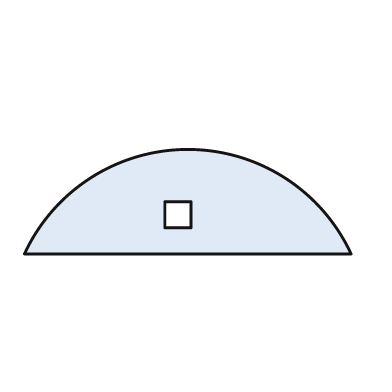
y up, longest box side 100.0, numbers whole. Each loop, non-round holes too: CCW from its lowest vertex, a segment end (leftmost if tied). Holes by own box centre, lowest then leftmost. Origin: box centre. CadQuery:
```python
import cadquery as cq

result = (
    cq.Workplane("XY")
    .moveTo(-50.0, -16.0)
    .lineTo(50.0, -16.0)
    .threePointArc((0.0, 16.0), (-50.0, -16.0))
    .close()
    .moveTo(-7.0, -8.0)
    .lineTo(1.0, -8.0)
    .lineTo(1.0, 0.0)
    .lineTo(-7.0, 0.0)
    .close()
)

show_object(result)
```